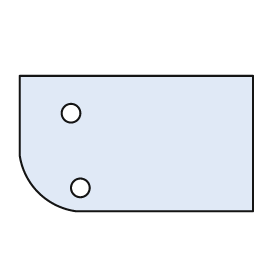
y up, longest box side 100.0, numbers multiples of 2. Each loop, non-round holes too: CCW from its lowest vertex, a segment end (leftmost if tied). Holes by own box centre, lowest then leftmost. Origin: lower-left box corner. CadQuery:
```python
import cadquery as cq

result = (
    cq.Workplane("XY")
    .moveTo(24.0, 0.0)
    .lineTo(100.0, 0.0)
    .lineTo(100.0, 58.0)
    .lineTo(0.0, 58.0)
    .lineTo(0.0, 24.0)
    .threePointArc((8.0, 8.0), (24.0, 0.0))
    .close()
    .moveTo(26.0, 10.0)
    .circle(4.0)
    .moveTo(22.0, 42.0)
    .circle(4.0)
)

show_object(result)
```